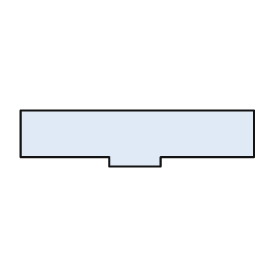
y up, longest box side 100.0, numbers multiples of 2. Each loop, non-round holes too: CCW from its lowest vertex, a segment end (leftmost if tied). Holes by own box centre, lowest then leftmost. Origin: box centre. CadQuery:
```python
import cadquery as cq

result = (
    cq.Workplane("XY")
    .moveTo(-12.0, -12.0)
    .lineTo(10.0, -12.0)
    .lineTo(10.0, -8.0)
    .lineTo(50.0, -8.0)
    .lineTo(50.0, 12.0)
    .lineTo(-50.0, 12.0)
    .lineTo(-50.0, -8.0)
    .lineTo(-12.0, -8.0)
    .close()
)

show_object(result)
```